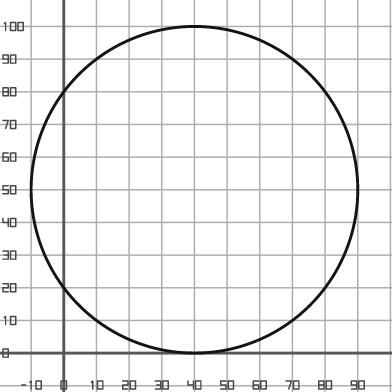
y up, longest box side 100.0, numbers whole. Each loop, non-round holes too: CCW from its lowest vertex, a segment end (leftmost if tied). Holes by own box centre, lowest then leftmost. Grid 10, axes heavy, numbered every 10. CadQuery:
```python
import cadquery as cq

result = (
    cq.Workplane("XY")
    .moveTo(40.0, 50.0)
    .circle(50.0)
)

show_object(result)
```